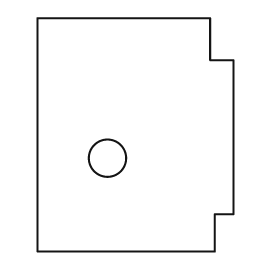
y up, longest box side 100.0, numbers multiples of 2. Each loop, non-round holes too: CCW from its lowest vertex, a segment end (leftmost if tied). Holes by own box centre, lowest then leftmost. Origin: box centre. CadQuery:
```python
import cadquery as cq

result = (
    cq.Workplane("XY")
    .moveTo(-42.0, -50.0)
    .lineTo(34.0, -50.0)
    .lineTo(34.0, -34.0)
    .lineTo(42.0, -34.0)
    .lineTo(42.0, 32.0)
    .lineTo(32.0, 32.0)
    .lineTo(32.0, 50.0)
    .lineTo(-42.0, 50.0)
    .close()
    .moveTo(-12.0, -10.0)
    .circle(8.0)
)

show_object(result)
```